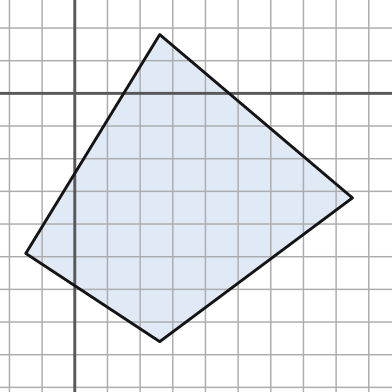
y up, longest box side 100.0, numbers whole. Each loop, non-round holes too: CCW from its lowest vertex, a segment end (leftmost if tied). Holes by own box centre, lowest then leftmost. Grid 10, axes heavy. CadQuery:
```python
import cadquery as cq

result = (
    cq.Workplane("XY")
    .moveTo(26.0, -76.0)
    .lineTo(85.0, -32.0)
    .lineTo(26.0, 18.0)
    .lineTo(-15.0, -49.0)
    .close()
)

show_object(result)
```